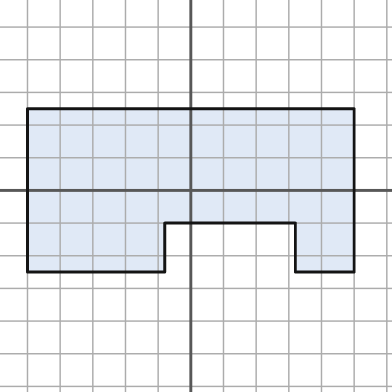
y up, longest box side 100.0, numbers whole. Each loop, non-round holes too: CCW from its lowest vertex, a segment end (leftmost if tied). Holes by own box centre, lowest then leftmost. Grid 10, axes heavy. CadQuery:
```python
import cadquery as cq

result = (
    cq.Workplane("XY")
    .moveTo(-50.0, -25.0)
    .lineTo(-8.0, -25.0)
    .lineTo(-8.0, -10.0)
    .lineTo(32.0, -10.0)
    .lineTo(32.0, -25.0)
    .lineTo(50.0, -25.0)
    .lineTo(50.0, 25.0)
    .lineTo(-50.0, 25.0)
    .close()
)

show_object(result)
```